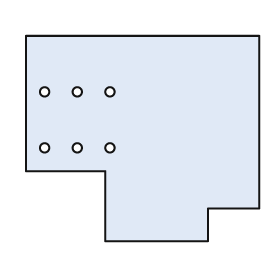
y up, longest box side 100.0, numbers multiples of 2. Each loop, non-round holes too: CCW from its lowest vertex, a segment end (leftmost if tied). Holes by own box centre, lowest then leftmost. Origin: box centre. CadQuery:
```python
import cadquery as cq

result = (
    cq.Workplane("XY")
    .moveTo(-16.0, -44.0)
    .lineTo(28.0, -44.0)
    .lineTo(28.0, -30.0)
    .lineTo(50.0, -30.0)
    .lineTo(50.0, 44.0)
    .lineTo(-50.0, 44.0)
    .lineTo(-50.0, -14.0)
    .lineTo(-16.0, -14.0)
    .close()
    .moveTo(-42.0, -4.0)
    .circle(2.0)
    .moveTo(-28.0, -4.0)
    .circle(2.0)
    .moveTo(-14.0, -4.0)
    .circle(2.0)
    .moveTo(-42.0, 20.0)
    .circle(2.0)
    .moveTo(-28.0, 20.0)
    .circle(2.0)
    .moveTo(-14.0, 20.0)
    .circle(2.0)
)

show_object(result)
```